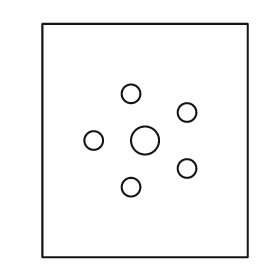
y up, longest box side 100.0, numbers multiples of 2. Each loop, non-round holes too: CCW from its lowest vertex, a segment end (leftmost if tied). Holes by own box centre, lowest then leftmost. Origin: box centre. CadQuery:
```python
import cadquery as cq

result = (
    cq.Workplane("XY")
    .moveTo(-44.0, -50.0)
    .lineTo(44.0, -50.0)
    .lineTo(44.0, 50.0)
    .lineTo(-44.0, 50.0)
    .close()
    .moveTo(-6.0, -20.0)
    .circle(4.0)
    .moveTo(18.0, -12.0)
    .circle(4.0)
    .moveTo(-22.0, 0.0)
    .circle(4.0)
    .moveTo(0.0, 0.0)
    .circle(6.0)
    .moveTo(18.0, 12.0)
    .circle(4.0)
    .moveTo(-6.0, 20.0)
    .circle(4.0)
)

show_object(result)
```